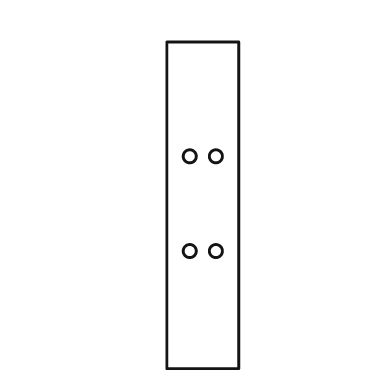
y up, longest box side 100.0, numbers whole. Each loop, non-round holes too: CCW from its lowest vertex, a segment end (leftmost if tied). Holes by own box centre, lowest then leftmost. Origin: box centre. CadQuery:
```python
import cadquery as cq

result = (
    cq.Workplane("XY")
    .moveTo(-11.0, -50.0)
    .lineTo(11.0, -50.0)
    .lineTo(11.0, 50.0)
    .lineTo(-11.0, 50.0)
    .close()
    .moveTo(-4.0, -14.0)
    .circle(2.0)
    .moveTo(4.0, -14.0)
    .circle(2.0)
    .moveTo(-4.0, 15.0)
    .circle(2.0)
    .moveTo(4.0, 15.0)
    .circle(2.0)
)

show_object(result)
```